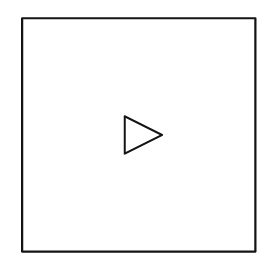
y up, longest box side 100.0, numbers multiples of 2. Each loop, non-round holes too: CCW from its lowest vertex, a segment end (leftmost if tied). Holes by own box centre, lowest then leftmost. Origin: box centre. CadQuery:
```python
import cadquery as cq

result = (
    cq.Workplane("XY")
    .moveTo(-50.0, -50.0)
    .lineTo(50.0, -50.0)
    .lineTo(50.0, 50.0)
    .lineTo(-50.0, 50.0)
    .close()
    .moveTo(-6.0, -8.0)
    .lineTo(10.0, 0.0)
    .lineTo(-6.0, 8.0)
    .close()
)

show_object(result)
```